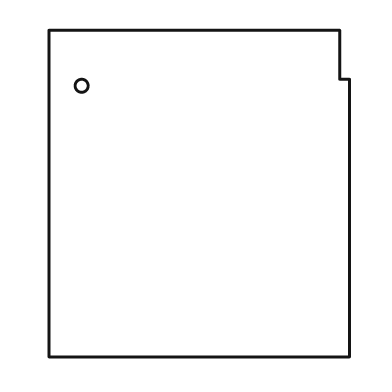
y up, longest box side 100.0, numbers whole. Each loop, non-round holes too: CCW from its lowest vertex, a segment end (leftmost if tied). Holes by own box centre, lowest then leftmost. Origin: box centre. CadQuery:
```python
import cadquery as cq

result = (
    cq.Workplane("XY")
    .moveTo(-46.0, -50.0)
    .lineTo(46.0, -50.0)
    .lineTo(46.0, 35.0)
    .lineTo(43.0, 35.0)
    .lineTo(43.0, 50.0)
    .lineTo(-46.0, 50.0)
    .close()
    .moveTo(-36.0, 33.0)
    .circle(2.0)
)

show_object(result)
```